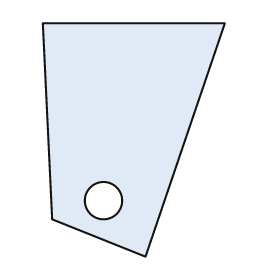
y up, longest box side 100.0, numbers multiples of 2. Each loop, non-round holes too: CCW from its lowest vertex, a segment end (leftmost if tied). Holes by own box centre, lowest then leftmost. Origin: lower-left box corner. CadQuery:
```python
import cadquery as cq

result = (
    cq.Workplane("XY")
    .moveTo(44.0, 0.0)
    .lineTo(78.0, 100.0)
    .lineTo(0.0, 100.0)
    .lineTo(4.0, 16.0)
    .close()
    .moveTo(26.0, 24.0)
    .circle(8.0)
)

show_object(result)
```